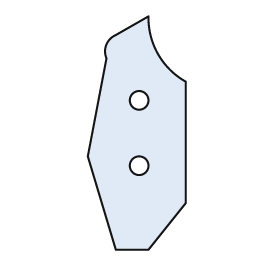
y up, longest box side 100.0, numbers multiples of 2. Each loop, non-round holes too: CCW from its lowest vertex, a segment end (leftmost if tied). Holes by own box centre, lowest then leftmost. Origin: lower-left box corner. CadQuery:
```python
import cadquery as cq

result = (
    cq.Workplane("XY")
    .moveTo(12.0, 0.0)
    .lineTo(26.0, 0.0)
    .lineTo(42.0, 20.0)
    .lineTo(42.0, 72.0)
    .threePointArc((30.0, 84.0), (26.0, 100.0))
    .lineTo(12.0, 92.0)
    .threePointArc((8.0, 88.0), (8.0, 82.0))
    .lineTo(0.0, 40.0)
    .close()
    .moveTo(22.0, 36.0)
    .circle(4.0)
    .moveTo(22.0, 64.0)
    .circle(4.0)
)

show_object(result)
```